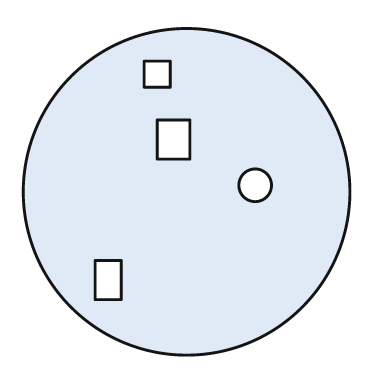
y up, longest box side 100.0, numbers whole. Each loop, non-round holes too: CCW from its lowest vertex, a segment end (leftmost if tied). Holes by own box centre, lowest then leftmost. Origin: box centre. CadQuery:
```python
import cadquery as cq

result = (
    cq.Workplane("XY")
    .moveTo(0.0, 0.0)
    .circle(50.0)
    .moveTo(-28.0, -33.0)
    .lineTo(-20.0, -33.0)
    .lineTo(-20.0, -21.0)
    .lineTo(-28.0, -21.0)
    .close()
    .moveTo(21.0, 2.0)
    .circle(5.0)
    .moveTo(-9.0, 10.0)
    .lineTo(1.0, 10.0)
    .lineTo(1.0, 22.0)
    .lineTo(-9.0, 22.0)
    .close()
    .moveTo(-13.0, 32.0)
    .lineTo(-5.0, 32.0)
    .lineTo(-5.0, 40.0)
    .lineTo(-13.0, 40.0)
    .close()
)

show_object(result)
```